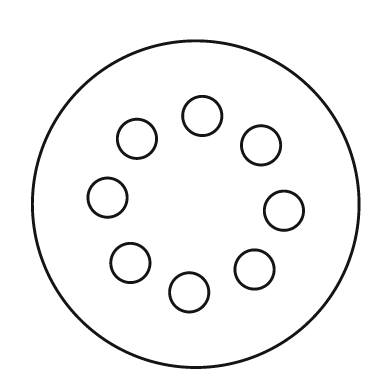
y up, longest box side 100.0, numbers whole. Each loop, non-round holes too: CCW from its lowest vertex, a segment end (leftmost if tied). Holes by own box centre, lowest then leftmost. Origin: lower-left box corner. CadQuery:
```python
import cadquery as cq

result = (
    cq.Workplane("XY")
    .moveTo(50.0, 50.0)
    .circle(50.0)
    .moveTo(48.0, 23.0)
    .circle(6.0)
    .moveTo(68.0, 30.0)
    .circle(6.0)
    .moveTo(30.0, 32.0)
    .circle(6.0)
    .moveTo(77.0, 48.0)
    .circle(6.0)
    .moveTo(23.0, 52.0)
    .circle(6.0)
    .moveTo(70.0, 68.0)
    .circle(6.0)
    .moveTo(32.0, 70.0)
    .circle(6.0)
    .moveTo(52.0, 77.0)
    .circle(6.0)
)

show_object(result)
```